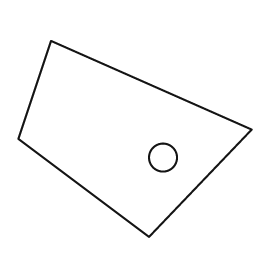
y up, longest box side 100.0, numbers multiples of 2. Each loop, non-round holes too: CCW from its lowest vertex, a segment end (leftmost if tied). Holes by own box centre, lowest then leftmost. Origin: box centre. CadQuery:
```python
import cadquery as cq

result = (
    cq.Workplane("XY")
    .moveTo(6.0, -42.0)
    .lineTo(50.0, 4.0)
    .lineTo(-36.0, 42.0)
    .lineTo(-50.0, 0.0)
    .close()
    .moveTo(12.0, -8.0)
    .circle(6.0)
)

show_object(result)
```